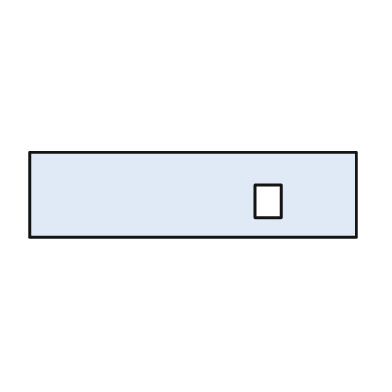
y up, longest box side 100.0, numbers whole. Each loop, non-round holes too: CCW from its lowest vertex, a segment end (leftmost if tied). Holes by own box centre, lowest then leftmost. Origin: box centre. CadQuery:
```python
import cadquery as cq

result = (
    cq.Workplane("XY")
    .moveTo(-50.0, -13.0)
    .lineTo(50.0, -13.0)
    .lineTo(50.0, 13.0)
    .lineTo(-50.0, 13.0)
    .close()
    .moveTo(19.0, -7.0)
    .lineTo(27.0, -7.0)
    .lineTo(27.0, 3.0)
    .lineTo(19.0, 3.0)
    .close()
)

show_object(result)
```